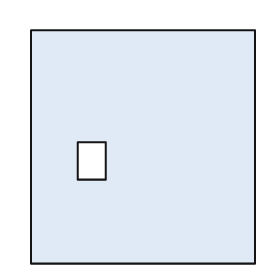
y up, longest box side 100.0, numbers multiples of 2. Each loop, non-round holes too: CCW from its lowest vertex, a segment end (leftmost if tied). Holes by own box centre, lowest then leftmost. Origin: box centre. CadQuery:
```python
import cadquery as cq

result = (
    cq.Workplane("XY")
    .moveTo(-48.0, -50.0)
    .lineTo(48.0, -50.0)
    .lineTo(48.0, 50.0)
    .lineTo(-48.0, 50.0)
    .close()
    .moveTo(-28.0, -14.0)
    .lineTo(-16.0, -14.0)
    .lineTo(-16.0, 2.0)
    .lineTo(-28.0, 2.0)
    .close()
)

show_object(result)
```